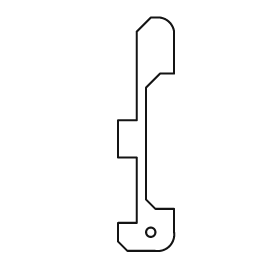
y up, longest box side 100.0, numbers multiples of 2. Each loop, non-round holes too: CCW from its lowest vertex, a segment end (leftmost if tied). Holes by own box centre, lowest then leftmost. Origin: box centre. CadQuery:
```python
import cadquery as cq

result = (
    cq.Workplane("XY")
    .moveTo(-8.0, -50.0)
    .lineTo(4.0, -50.0)
    .threePointArc((10.0, -48.0), (12.0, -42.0))
    .lineTo(12.0, -32.0)
    .lineTo(4.0, -32.0)
    .lineTo(0.0, -28.0)
    .lineTo(0.0, 20.0)
    .lineTo(6.0, 26.0)
    .lineTo(12.0, 26.0)
    .lineTo(12.0, 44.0)
    .threePointArc((10.0, 48.0), (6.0, 50.0))
    .lineTo(2.0, 50.0)
    .lineTo(-4.0, 44.0)
    .lineTo(-4.0, 6.0)
    .lineTo(-12.0, 6.0)
    .lineTo(-12.0, -10.0)
    .lineTo(-4.0, -10.0)
    .lineTo(-4.0, -38.0)
    .lineTo(-12.0, -38.0)
    .lineTo(-12.0, -46.0)
    .close()
    .moveTo(2.0, -42.0)
    .circle(2.0)
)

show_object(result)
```